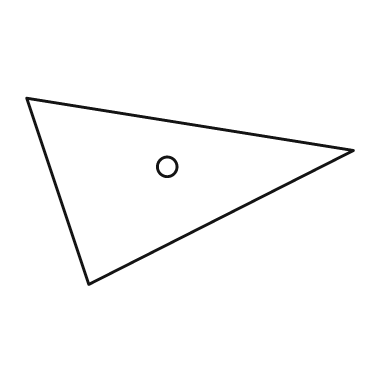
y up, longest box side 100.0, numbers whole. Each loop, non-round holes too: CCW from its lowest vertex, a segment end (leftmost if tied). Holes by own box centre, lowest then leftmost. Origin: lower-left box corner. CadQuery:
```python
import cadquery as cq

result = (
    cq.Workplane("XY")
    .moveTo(19.0, 0.0)
    .lineTo(100.0, 41.0)
    .lineTo(0.0, 57.0)
    .close()
    .moveTo(43.0, 36.0)
    .circle(3.0)
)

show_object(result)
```